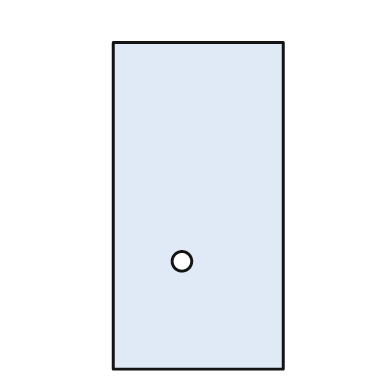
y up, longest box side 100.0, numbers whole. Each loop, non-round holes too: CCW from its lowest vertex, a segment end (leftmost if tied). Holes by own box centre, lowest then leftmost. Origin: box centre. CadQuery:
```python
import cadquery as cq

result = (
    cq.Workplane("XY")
    .moveTo(-26.0, -50.0)
    .lineTo(26.0, -50.0)
    .lineTo(26.0, 50.0)
    .lineTo(-26.0, 50.0)
    .close()
    .moveTo(-5.0, -17.0)
    .circle(3.0)
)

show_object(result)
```